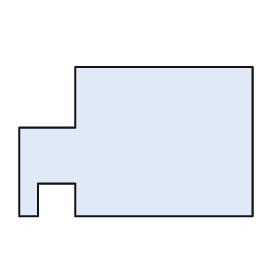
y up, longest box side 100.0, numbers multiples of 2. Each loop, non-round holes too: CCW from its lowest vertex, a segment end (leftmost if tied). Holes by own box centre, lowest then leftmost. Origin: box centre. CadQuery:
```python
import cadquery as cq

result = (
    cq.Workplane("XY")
    .moveTo(-50.0, -32.0)
    .lineTo(-42.0, -32.0)
    .lineTo(-42.0, -18.0)
    .lineTo(-26.0, -18.0)
    .lineTo(-26.0, -32.0)
    .lineTo(50.0, -32.0)
    .lineTo(50.0, 32.0)
    .lineTo(-26.0, 32.0)
    .lineTo(-26.0, 6.0)
    .lineTo(-50.0, 6.0)
    .close()
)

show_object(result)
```